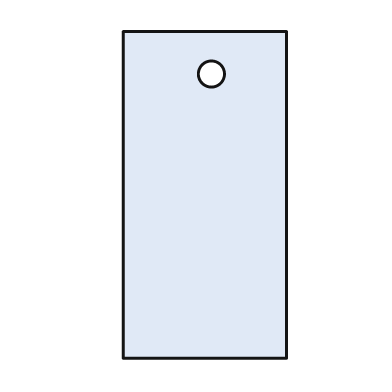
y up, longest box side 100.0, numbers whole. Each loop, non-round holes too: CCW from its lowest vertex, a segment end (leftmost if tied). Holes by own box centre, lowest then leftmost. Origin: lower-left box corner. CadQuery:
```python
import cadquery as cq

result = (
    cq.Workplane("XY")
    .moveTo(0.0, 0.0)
    .lineTo(50.0, 0.0)
    .lineTo(50.0, 100.0)
    .lineTo(0.0, 100.0)
    .close()
    .moveTo(27.0, 87.0)
    .circle(4.0)
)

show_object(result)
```